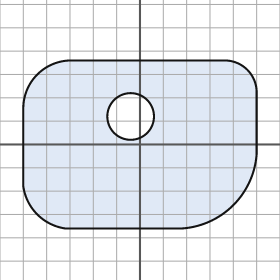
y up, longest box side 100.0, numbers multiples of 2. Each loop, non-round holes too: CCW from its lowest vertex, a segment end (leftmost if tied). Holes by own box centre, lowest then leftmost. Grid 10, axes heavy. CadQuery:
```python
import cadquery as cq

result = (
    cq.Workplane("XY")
    .moveTo(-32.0, -36.0)
    .lineTo(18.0, -36.0)
    .threePointArc((40.0, -26.0), (50.0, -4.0))
    .lineTo(50.0, 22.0)
    .threePointArc((46.0, 32.0), (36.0, 36.0))
    .lineTo(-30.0, 36.0)
    .threePointArc((-44.0, 30.0), (-50.0, 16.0))
    .lineTo(-50.0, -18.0)
    .threePointArc((-44.0, -30.0), (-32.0, -36.0))
    .close()
    .moveTo(-4.0, 12.0)
    .circle(10.0)
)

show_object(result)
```